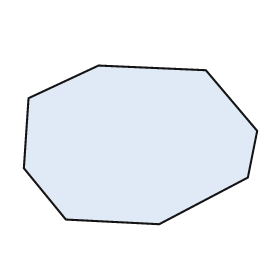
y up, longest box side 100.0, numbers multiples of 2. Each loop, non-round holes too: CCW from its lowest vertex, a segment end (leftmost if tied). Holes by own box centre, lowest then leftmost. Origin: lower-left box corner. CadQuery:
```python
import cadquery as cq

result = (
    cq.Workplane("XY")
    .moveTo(58.0, 0.0)
    .lineTo(96.0, 20.0)
    .lineTo(100.0, 40.0)
    .lineTo(78.0, 66.0)
    .lineTo(32.0, 68.0)
    .lineTo(2.0, 54.0)
    .lineTo(0.0, 24.0)
    .lineTo(18.0, 2.0)
    .close()
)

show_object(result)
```